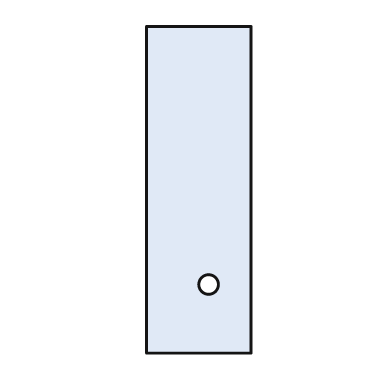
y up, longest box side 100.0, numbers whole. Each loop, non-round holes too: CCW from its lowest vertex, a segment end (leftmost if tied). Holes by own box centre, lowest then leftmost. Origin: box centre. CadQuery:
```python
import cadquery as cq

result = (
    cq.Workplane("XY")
    .moveTo(-16.0, -50.0)
    .lineTo(16.0, -50.0)
    .lineTo(16.0, 50.0)
    .lineTo(-16.0, 50.0)
    .close()
    .moveTo(3.0, -29.0)
    .circle(3.0)
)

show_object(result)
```